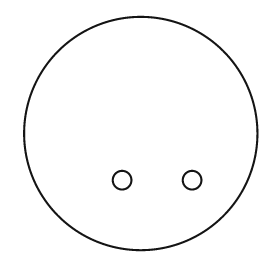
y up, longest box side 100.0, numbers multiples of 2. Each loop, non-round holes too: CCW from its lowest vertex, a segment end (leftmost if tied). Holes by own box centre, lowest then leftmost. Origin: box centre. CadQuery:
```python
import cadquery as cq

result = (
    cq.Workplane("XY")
    .moveTo(0.0, 0.0)
    .circle(50.0)
    .moveTo(-8.0, -20.0)
    .circle(4.0)
    .moveTo(22.0, -20.0)
    .circle(4.0)
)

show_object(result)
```